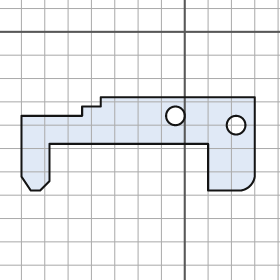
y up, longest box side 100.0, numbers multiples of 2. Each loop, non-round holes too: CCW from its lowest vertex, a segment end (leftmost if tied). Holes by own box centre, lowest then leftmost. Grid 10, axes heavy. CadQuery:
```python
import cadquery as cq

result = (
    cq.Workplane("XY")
    .moveTo(-66.0, -68.0)
    .lineTo(-62.0, -68.0)
    .lineTo(-58.0, -64.0)
    .lineTo(-58.0, -48.0)
    .lineTo(10.0, -48.0)
    .lineTo(10.0, -68.0)
    .lineTo(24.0, -68.0)
    .threePointArc((28.0, -66.0), (30.0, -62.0))
    .lineTo(30.0, -28.0)
    .lineTo(-36.0, -28.0)
    .lineTo(-36.0, -32.0)
    .lineTo(-44.0, -32.0)
    .lineTo(-44.0, -36.0)
    .lineTo(-70.0, -36.0)
    .lineTo(-70.0, -62.0)
    .close()
    .moveTo(22.0, -40.0)
    .circle(4.0)
    .moveTo(-4.0, -36.0)
    .circle(4.0)
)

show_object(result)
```